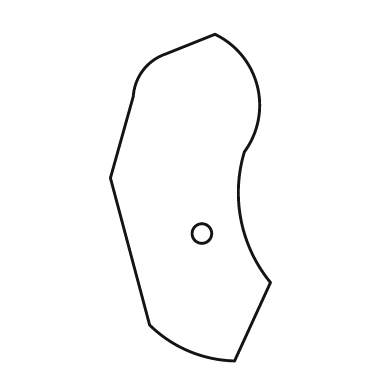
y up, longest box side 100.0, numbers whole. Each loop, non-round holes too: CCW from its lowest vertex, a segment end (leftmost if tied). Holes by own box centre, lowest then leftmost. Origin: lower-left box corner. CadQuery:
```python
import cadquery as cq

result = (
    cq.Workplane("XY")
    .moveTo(38.0, 0.0)
    .lineTo(49.0, 24.0)
    .threePointArc((40.0, 43.0), (41.0, 64.0))
    .threePointArc((45.0, 84.0), (32.0, 100.0))
    .lineTo(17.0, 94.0)
    .threePointArc((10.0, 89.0), (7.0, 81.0))
    .lineTo(0.0, 56.0)
    .lineTo(12.0, 11.0)
    .threePointArc((24.0, 3.0), (38.0, 0.0))
    .close()
    .moveTo(28.0, 39.0)
    .circle(3.0)
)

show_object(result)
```